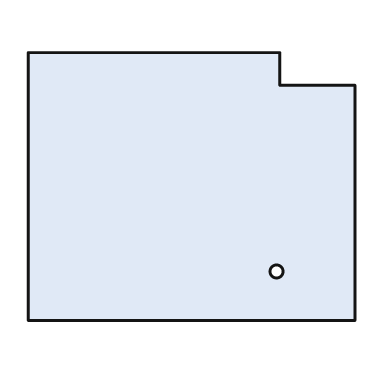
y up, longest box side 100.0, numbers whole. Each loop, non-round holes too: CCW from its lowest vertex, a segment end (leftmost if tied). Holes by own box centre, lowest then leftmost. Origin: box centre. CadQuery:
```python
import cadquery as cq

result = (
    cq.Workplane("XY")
    .moveTo(-50.0, -41.0)
    .lineTo(50.0, -41.0)
    .lineTo(50.0, 31.0)
    .lineTo(27.0, 31.0)
    .lineTo(27.0, 41.0)
    .lineTo(-50.0, 41.0)
    .close()
    .moveTo(26.0, -26.0)
    .circle(2.0)
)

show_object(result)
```